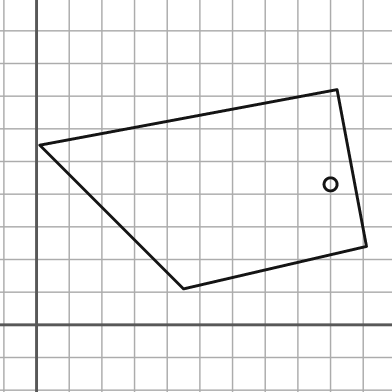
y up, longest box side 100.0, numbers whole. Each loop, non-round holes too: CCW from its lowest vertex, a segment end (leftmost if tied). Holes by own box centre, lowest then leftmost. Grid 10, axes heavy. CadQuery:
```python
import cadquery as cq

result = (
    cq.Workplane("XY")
    .moveTo(45.0, 11.0)
    .lineTo(101.0, 24.0)
    .lineTo(92.0, 72.0)
    .lineTo(1.0, 55.0)
    .close()
    .moveTo(90.0, 43.0)
    .circle(2.0)
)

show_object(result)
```